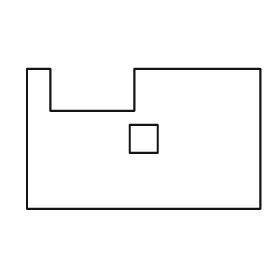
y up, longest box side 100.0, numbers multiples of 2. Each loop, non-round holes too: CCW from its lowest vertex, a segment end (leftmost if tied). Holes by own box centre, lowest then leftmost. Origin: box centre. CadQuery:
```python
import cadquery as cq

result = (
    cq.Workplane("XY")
    .moveTo(-50.0, -30.0)
    .lineTo(50.0, -30.0)
    .lineTo(50.0, 30.0)
    .lineTo(-4.0, 30.0)
    .lineTo(-4.0, 12.0)
    .lineTo(-40.0, 12.0)
    .lineTo(-40.0, 30.0)
    .lineTo(-50.0, 30.0)
    .close()
    .moveTo(-6.0, -6.0)
    .lineTo(6.0, -6.0)
    .lineTo(6.0, 6.0)
    .lineTo(-6.0, 6.0)
    .close()
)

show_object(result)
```